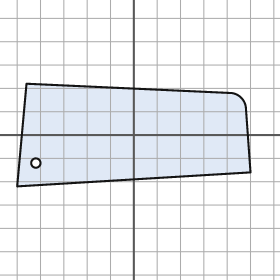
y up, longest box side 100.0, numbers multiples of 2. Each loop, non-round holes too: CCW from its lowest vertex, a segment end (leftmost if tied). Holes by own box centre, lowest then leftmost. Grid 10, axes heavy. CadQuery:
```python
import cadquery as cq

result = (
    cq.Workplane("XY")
    .moveTo(-50.0, -22.0)
    .lineTo(50.0, -16.0)
    .lineTo(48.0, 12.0)
    .threePointArc((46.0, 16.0), (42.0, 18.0))
    .lineTo(-46.0, 22.0)
    .close()
    .moveTo(-42.0, -12.0)
    .circle(2.0)
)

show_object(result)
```